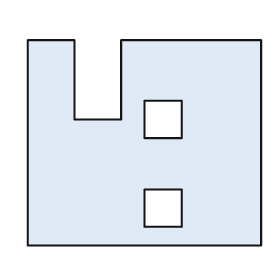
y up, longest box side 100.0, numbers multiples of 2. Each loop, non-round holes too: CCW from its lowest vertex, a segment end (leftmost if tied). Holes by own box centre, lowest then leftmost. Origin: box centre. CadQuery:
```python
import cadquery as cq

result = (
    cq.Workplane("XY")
    .moveTo(-50.0, -44.0)
    .lineTo(50.0, -44.0)
    .lineTo(50.0, 44.0)
    .lineTo(-10.0, 44.0)
    .lineTo(-10.0, 10.0)
    .lineTo(-30.0, 10.0)
    .lineTo(-30.0, 44.0)
    .lineTo(-50.0, 44.0)
    .close()
    .moveTo(0.0, -36.0)
    .lineTo(16.0, -36.0)
    .lineTo(16.0, -20.0)
    .lineTo(0.0, -20.0)
    .close()
    .moveTo(0.0, 2.0)
    .lineTo(16.0, 2.0)
    .lineTo(16.0, 18.0)
    .lineTo(0.0, 18.0)
    .close()
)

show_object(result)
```